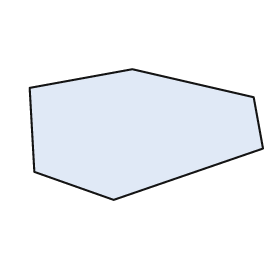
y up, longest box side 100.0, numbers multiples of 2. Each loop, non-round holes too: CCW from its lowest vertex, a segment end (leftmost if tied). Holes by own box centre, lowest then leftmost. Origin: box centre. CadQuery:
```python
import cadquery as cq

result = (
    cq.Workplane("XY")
    .moveTo(-14.0, -28.0)
    .lineTo(50.0, -6.0)
    .lineTo(46.0, 16.0)
    .lineTo(-6.0, 28.0)
    .lineTo(-50.0, 20.0)
    .lineTo(-48.0, -16.0)
    .close()
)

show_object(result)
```